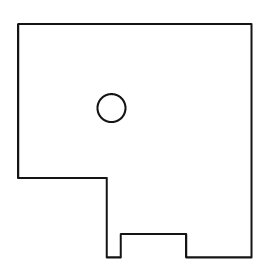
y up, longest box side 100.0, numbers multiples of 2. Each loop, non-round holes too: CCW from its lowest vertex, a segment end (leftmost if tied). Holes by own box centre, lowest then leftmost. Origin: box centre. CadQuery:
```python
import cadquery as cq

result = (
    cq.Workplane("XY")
    .moveTo(-12.0, -50.0)
    .lineTo(-6.0, -50.0)
    .lineTo(-6.0, -40.0)
    .lineTo(22.0, -40.0)
    .lineTo(22.0, -50.0)
    .lineTo(50.0, -50.0)
    .lineTo(50.0, 50.0)
    .lineTo(-50.0, 50.0)
    .lineTo(-50.0, -16.0)
    .lineTo(-12.0, -16.0)
    .close()
    .moveTo(-10.0, 14.0)
    .circle(6.0)
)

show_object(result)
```